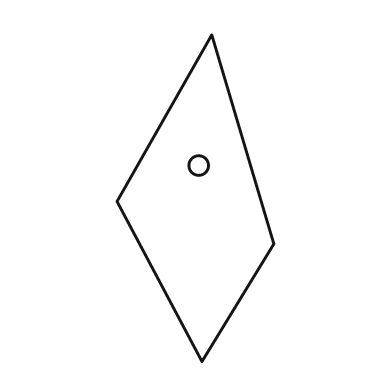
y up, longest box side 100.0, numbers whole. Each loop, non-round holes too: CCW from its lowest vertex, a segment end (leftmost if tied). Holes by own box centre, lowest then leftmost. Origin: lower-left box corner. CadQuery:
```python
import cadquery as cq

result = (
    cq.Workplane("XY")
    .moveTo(26.0, 0.0)
    .lineTo(48.0, 36.0)
    .lineTo(29.0, 100.0)
    .lineTo(0.0, 49.0)
    .close()
    .moveTo(25.0, 60.0)
    .circle(3.0)
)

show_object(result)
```